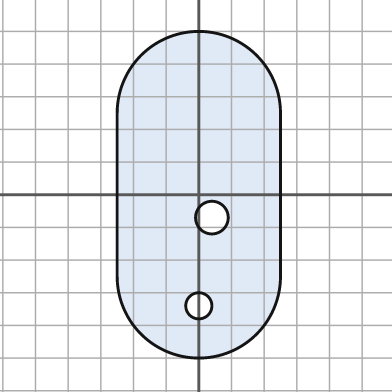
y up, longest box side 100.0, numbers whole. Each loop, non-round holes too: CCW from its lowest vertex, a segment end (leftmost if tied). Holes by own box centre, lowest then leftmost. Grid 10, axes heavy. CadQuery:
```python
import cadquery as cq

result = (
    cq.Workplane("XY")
    .moveTo(-25.0, -25.0)
    .threePointArc((0.0, -50.0), (25.0, -25.0))
    .lineTo(25.0, 25.0)
    .threePointArc((0.0, 50.0), (-25.0, 25.0))
    .close()
    .moveTo(0.0, -34.0)
    .circle(4.0)
    .moveTo(4.0, -7.0)
    .circle(5.0)
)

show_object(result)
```